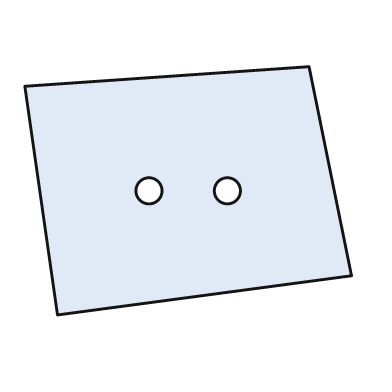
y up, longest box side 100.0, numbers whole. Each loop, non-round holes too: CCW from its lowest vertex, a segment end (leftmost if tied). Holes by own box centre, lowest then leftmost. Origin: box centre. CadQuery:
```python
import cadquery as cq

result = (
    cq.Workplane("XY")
    .moveTo(-40.0, -38.0)
    .lineTo(50.0, -26.0)
    .lineTo(37.0, 38.0)
    .lineTo(-50.0, 32.0)
    .close()
    .moveTo(-12.0, 0.0)
    .circle(4.0)
    .moveTo(12.0, 0.0)
    .circle(4.0)
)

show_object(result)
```